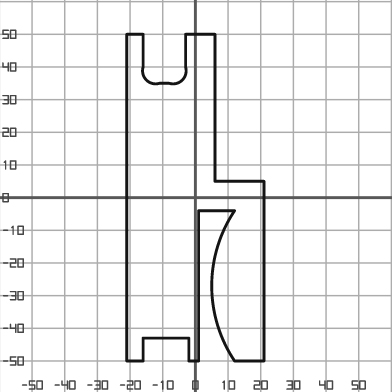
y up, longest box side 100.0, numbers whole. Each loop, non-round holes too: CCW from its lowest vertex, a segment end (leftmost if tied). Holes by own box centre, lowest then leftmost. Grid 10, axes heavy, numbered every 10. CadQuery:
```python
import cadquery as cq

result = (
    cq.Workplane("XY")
    .moveTo(-21.0, -50.0)
    .lineTo(-16.0, -50.0)
    .lineTo(-16.0, -43.0)
    .lineTo(-2.0, -43.0)
    .lineTo(-2.0, -50.0)
    .lineTo(1.0, -50.0)
    .lineTo(1.0, -4.0)
    .lineTo(12.0, -4.0)
    .threePointArc((5.0, -27.0), (12.0, -50.0))
    .lineTo(21.0, -50.0)
    .lineTo(21.0, 5.0)
    .lineTo(6.0, 5.0)
    .lineTo(6.0, 50.0)
    .lineTo(-3.0, 50.0)
    .lineTo(-3.0, 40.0)
    .threePointArc((-4.0, 36.0), (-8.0, 35.0))
    .lineTo(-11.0, 35.0)
    .threePointArc((-15.0, 36.0), (-16.0, 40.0))
    .lineTo(-16.0, 50.0)
    .lineTo(-21.0, 50.0)
    .close()
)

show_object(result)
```